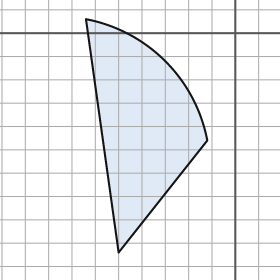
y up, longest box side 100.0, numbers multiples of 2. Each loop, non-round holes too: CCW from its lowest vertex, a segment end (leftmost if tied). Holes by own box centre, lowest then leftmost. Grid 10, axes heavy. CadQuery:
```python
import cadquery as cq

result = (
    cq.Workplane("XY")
    .moveTo(-50.0, -94.0)
    .lineTo(-12.0, -46.0)
    .threePointArc((-30.0, -12.0), (-64.0, 6.0))
    .close()
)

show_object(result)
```